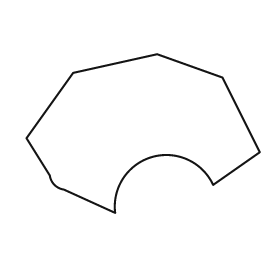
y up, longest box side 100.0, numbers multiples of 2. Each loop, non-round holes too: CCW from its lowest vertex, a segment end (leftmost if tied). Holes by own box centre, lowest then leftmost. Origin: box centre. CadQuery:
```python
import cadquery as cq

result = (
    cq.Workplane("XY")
    .moveTo(-12.0, -34.0)
    .threePointArc((4.0, -10.0), (30.0, -22.0))
    .lineTo(50.0, -8.0)
    .lineTo(34.0, 24.0)
    .lineTo(6.0, 34.0)
    .lineTo(-30.0, 26.0)
    .lineTo(-50.0, -2.0)
    .lineTo(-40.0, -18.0)
    .threePointArc((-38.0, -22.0), (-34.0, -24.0))
    .close()
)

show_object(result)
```